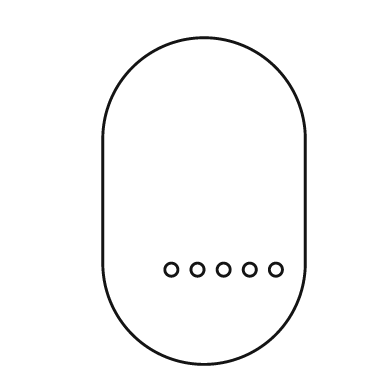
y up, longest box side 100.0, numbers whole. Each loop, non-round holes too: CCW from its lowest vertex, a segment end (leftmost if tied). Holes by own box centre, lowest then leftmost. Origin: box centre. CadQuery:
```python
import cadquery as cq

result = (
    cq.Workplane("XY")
    .moveTo(-31.0, -19.0)
    .threePointArc((0.0, -50.0), (31.0, -19.0))
    .lineTo(31.0, 19.0)
    .threePointArc((0.0, 50.0), (-31.0, 19.0))
    .close()
    .moveTo(-10.0, -21.0)
    .circle(2.0)
    .moveTo(-2.0, -21.0)
    .circle(2.0)
    .moveTo(6.0, -21.0)
    .circle(2.0)
    .moveTo(14.0, -21.0)
    .circle(2.0)
    .moveTo(22.0, -21.0)
    .circle(2.0)
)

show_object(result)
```